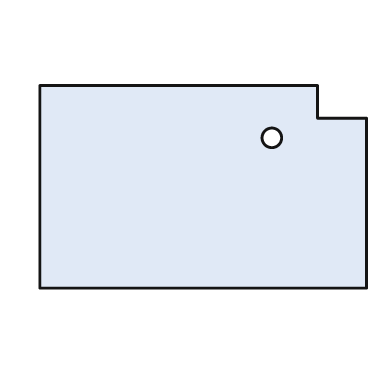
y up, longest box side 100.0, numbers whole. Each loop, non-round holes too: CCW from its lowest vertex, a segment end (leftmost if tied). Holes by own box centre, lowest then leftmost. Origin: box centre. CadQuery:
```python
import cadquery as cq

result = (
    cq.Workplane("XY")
    .moveTo(-50.0, -31.0)
    .lineTo(50.0, -31.0)
    .lineTo(50.0, 21.0)
    .lineTo(35.0, 21.0)
    .lineTo(35.0, 31.0)
    .lineTo(-50.0, 31.0)
    .close()
    .moveTo(21.0, 15.0)
    .circle(3.0)
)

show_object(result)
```